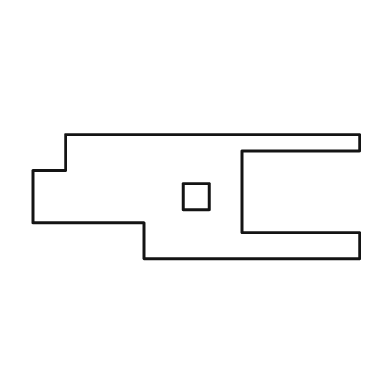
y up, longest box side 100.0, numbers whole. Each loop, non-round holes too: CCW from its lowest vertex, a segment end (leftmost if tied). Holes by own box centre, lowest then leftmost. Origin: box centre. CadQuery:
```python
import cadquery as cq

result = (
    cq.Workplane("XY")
    .moveTo(-16.0, -19.0)
    .lineTo(50.0, -19.0)
    .lineTo(50.0, -11.0)
    .lineTo(14.0, -11.0)
    .lineTo(14.0, 14.0)
    .lineTo(50.0, 14.0)
    .lineTo(50.0, 19.0)
    .lineTo(-40.0, 19.0)
    .lineTo(-40.0, 8.0)
    .lineTo(-50.0, 8.0)
    .lineTo(-50.0, -8.0)
    .lineTo(-16.0, -8.0)
    .close()
    .moveTo(-4.0, -4.0)
    .lineTo(4.0, -4.0)
    .lineTo(4.0, 4.0)
    .lineTo(-4.0, 4.0)
    .close()
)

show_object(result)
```